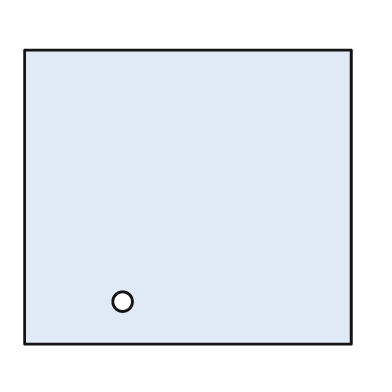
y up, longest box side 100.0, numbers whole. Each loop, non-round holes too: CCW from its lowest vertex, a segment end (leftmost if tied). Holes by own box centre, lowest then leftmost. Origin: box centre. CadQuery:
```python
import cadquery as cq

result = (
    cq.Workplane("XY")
    .moveTo(-50.0, -45.0)
    .lineTo(50.0, -45.0)
    .lineTo(50.0, 45.0)
    .lineTo(-50.0, 45.0)
    .close()
    .moveTo(-20.0, -32.0)
    .circle(3.0)
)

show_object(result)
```